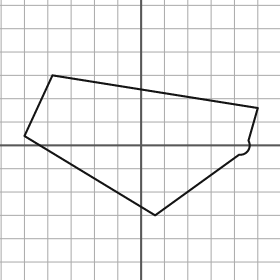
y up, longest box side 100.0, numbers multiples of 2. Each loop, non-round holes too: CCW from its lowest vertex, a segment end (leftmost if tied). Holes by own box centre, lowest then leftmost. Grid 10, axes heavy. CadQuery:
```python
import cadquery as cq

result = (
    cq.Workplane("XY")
    .moveTo(6.0, -30.0)
    .lineTo(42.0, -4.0)
    .threePointArc((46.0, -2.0), (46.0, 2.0))
    .lineTo(50.0, 16.0)
    .lineTo(-38.0, 30.0)
    .lineTo(-50.0, 4.0)
    .close()
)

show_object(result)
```